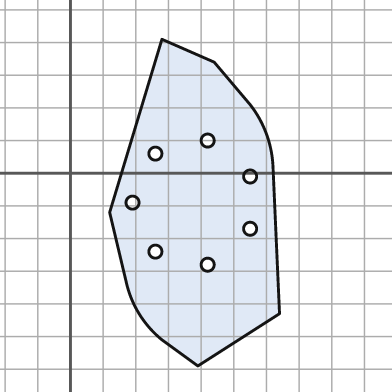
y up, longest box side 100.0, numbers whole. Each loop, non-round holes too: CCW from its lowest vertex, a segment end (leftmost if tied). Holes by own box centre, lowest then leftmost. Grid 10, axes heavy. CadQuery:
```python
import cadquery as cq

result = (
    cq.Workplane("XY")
    .moveTo(39.0, -59.0)
    .lineTo(64.0, -43.0)
    .lineTo(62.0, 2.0)
    .threePointArc((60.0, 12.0), (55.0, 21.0))
    .lineTo(44.0, 34.0)
    .lineTo(28.0, 41.0)
    .lineTo(12.0, -12.0)
    .lineTo(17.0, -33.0)
    .threePointArc((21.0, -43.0), (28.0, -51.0))
    .close()
    .moveTo(42.0, -28.0)
    .circle(2.0)
    .moveTo(26.0, -24.0)
    .circle(2.0)
    .moveTo(55.0, -17.0)
    .circle(2.0)
    .moveTo(19.0, -9.0)
    .circle(2.0)
    .moveTo(55.0, -1.0)
    .circle(2.0)
    .moveTo(26.0, 6.0)
    .circle(2.0)
    .moveTo(42.0, 10.0)
    .circle(2.0)
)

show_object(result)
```